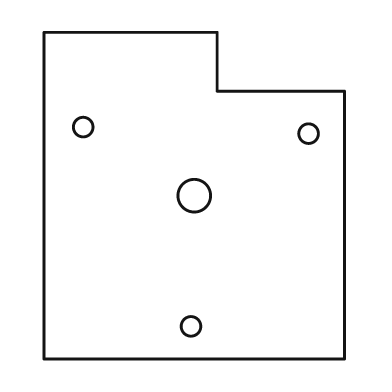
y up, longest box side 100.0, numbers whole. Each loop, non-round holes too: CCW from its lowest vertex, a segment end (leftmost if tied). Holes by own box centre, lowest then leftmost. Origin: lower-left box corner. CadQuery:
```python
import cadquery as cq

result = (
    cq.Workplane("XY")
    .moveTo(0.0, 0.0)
    .lineTo(92.0, 0.0)
    .lineTo(92.0, 82.0)
    .lineTo(53.0, 82.0)
    .lineTo(53.0, 100.0)
    .lineTo(0.0, 100.0)
    .close()
    .moveTo(45.0, 10.0)
    .circle(3.0)
    .moveTo(46.0, 50.0)
    .circle(5.0)
    .moveTo(81.0, 69.0)
    .circle(3.0)
    .moveTo(12.0, 71.0)
    .circle(3.0)
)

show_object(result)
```